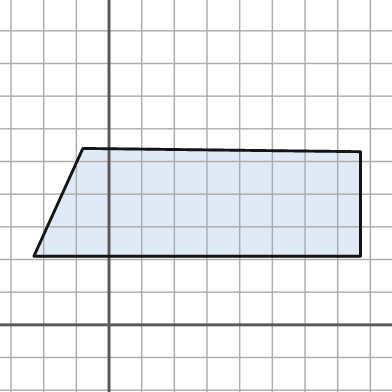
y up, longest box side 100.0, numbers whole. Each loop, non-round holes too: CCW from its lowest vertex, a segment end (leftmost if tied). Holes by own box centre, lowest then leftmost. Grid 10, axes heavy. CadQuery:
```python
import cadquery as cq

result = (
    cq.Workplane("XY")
    .moveTo(-23.0, 21.0)
    .lineTo(77.0, 21.0)
    .lineTo(77.0, 53.0)
    .lineTo(-8.0, 54.0)
    .close()
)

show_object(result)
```